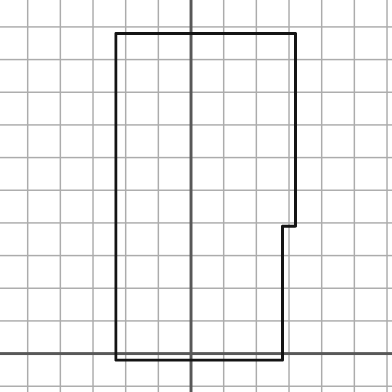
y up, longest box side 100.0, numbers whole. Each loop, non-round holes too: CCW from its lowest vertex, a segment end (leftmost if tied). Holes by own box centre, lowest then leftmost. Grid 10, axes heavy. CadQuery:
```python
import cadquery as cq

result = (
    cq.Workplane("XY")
    .moveTo(-23.0, -2.0)
    .lineTo(28.0, -2.0)
    .lineTo(28.0, 39.0)
    .lineTo(32.0, 39.0)
    .lineTo(32.0, 98.0)
    .lineTo(-23.0, 98.0)
    .close()
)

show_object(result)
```